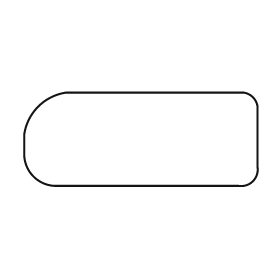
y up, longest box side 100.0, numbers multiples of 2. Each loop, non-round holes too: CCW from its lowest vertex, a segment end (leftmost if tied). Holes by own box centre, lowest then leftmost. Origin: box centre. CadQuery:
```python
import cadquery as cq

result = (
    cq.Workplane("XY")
    .moveTo(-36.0, -20.0)
    .lineTo(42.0, -20.0)
    .threePointArc((48.0, -18.0), (50.0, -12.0))
    .lineTo(50.0, 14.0)
    .threePointArc((48.0, 18.0), (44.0, 20.0))
    .lineTo(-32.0, 20.0)
    .threePointArc((-44.0, 14.0), (-50.0, 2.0))
    .lineTo(-50.0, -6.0)
    .threePointArc((-46.0, -16.0), (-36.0, -20.0))
    .close()
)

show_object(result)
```